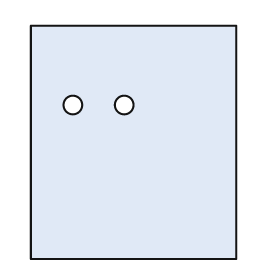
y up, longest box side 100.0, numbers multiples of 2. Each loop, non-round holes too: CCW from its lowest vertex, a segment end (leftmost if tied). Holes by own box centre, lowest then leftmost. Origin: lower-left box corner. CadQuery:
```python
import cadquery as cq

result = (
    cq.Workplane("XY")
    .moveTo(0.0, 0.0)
    .lineTo(88.0, 0.0)
    .lineTo(88.0, 100.0)
    .lineTo(0.0, 100.0)
    .close()
    .moveTo(18.0, 66.0)
    .circle(4.0)
    .moveTo(40.0, 66.0)
    .circle(4.0)
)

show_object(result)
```